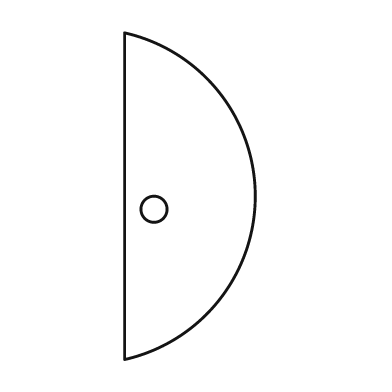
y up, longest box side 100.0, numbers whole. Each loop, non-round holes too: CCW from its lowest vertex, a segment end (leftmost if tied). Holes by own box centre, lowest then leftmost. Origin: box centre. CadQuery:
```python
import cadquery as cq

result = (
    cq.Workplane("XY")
    .moveTo(-20.0, -50.0)
    .threePointArc((20.0, 0.0), (-20.0, 50.0))
    .close()
    .moveTo(-11.0, -4.0)
    .circle(4.0)
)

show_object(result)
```